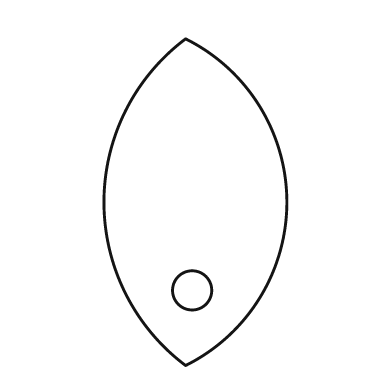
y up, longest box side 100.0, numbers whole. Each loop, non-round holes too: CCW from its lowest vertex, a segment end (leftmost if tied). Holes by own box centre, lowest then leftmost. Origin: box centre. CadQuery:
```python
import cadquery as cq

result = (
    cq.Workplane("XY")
    .moveTo(-3.0, -50.0)
    .threePointArc((28.0, 0.0), (-3.0, 50.0))
    .threePointArc((-28.0, 0.0), (-3.0, -50.0))
    .close()
    .moveTo(-1.0, -27.0)
    .circle(6.0)
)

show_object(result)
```